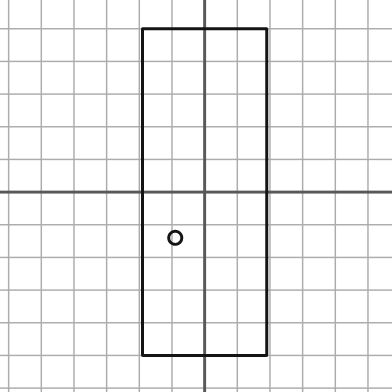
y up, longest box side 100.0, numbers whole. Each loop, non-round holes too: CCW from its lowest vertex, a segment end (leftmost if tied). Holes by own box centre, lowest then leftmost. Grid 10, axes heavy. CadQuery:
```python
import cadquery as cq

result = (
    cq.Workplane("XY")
    .moveTo(-19.0, -50.0)
    .lineTo(19.0, -50.0)
    .lineTo(19.0, 50.0)
    .lineTo(-19.0, 50.0)
    .close()
    .moveTo(-9.0, -14.0)
    .circle(2.0)
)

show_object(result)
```